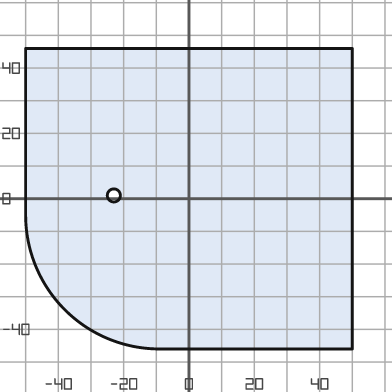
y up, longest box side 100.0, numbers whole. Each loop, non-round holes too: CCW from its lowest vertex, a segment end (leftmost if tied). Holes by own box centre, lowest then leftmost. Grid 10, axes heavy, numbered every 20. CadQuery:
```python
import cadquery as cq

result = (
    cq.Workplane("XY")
    .moveTo(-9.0, -46.0)
    .lineTo(50.0, -46.0)
    .lineTo(50.0, 46.0)
    .lineTo(-50.0, 46.0)
    .lineTo(-50.0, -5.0)
    .threePointArc((-38.0, -34.0), (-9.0, -46.0))
    .close()
    .moveTo(-23.0, 1.0)
    .circle(2.0)
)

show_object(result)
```